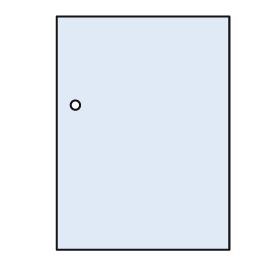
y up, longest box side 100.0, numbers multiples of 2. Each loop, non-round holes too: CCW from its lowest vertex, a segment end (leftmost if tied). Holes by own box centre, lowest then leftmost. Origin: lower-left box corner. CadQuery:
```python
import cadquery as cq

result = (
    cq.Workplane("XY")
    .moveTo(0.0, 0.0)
    .lineTo(74.0, 0.0)
    .lineTo(74.0, 100.0)
    .lineTo(0.0, 100.0)
    .close()
    .moveTo(8.0, 62.0)
    .circle(2.0)
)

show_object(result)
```